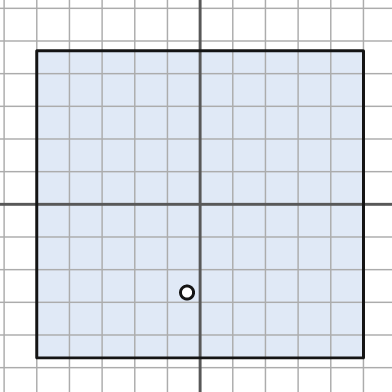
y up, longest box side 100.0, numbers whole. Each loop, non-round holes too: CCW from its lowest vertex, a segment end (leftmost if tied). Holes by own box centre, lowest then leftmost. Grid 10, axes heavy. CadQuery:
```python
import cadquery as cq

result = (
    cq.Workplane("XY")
    .moveTo(-50.0, -47.0)
    .lineTo(50.0, -47.0)
    .lineTo(50.0, 47.0)
    .lineTo(-50.0, 47.0)
    .close()
    .moveTo(-4.0, -27.0)
    .circle(2.0)
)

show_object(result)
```